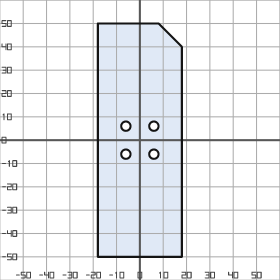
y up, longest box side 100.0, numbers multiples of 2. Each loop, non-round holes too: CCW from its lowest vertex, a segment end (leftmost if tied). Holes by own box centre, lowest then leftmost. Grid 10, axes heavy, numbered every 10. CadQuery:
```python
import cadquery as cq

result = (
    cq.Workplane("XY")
    .moveTo(-18.0, -50.0)
    .lineTo(18.0, -50.0)
    .lineTo(18.0, 40.0)
    .lineTo(8.0, 50.0)
    .lineTo(-18.0, 50.0)
    .close()
    .moveTo(-6.0, -6.0)
    .circle(2.0)
    .moveTo(6.0, -6.0)
    .circle(2.0)
    .moveTo(-6.0, 6.0)
    .circle(2.0)
    .moveTo(6.0, 6.0)
    .circle(2.0)
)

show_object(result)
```